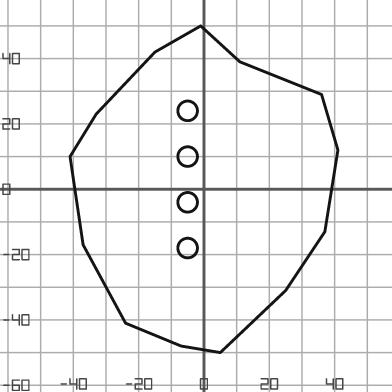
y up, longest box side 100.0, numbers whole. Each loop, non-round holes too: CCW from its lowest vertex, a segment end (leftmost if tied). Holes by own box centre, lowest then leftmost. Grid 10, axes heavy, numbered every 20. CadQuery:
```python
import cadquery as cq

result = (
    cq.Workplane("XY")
    .moveTo(5.0, -50.0)
    .lineTo(25.0, -31.0)
    .lineTo(37.0, -13.0)
    .lineTo(41.0, 12.0)
    .lineTo(36.0, 29.0)
    .lineTo(11.0, 39.0)
    .lineTo(-1.0, 50.0)
    .lineTo(-15.0, 42.0)
    .lineTo(-33.0, 23.0)
    .lineTo(-41.0, 10.0)
    .lineTo(-37.0, -17.0)
    .lineTo(-24.0, -41.0)
    .lineTo(-7.0, -48.0)
    .close()
    .moveTo(-5.0, -18.0)
    .circle(3.0)
    .moveTo(-5.0, -4.0)
    .circle(3.0)
    .moveTo(-5.0, 10.0)
    .circle(3.0)
    .moveTo(-5.0, 24.0)
    .circle(3.0)
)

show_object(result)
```